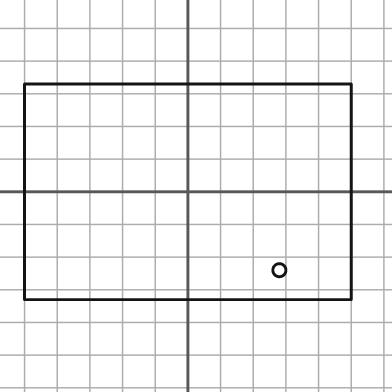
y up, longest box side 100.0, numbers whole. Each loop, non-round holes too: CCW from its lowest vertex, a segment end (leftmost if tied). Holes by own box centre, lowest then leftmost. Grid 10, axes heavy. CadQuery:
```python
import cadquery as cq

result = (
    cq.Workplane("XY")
    .moveTo(-50.0, -33.0)
    .lineTo(50.0, -33.0)
    .lineTo(50.0, 33.0)
    .lineTo(-50.0, 33.0)
    .close()
    .moveTo(28.0, -24.0)
    .circle(2.0)
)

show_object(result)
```